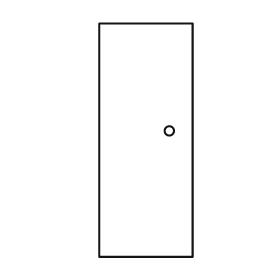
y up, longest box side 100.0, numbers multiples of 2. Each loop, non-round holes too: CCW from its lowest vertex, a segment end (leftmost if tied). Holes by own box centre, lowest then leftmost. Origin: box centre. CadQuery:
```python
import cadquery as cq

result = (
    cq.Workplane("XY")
    .moveTo(-20.0, -50.0)
    .lineTo(20.0, -50.0)
    .lineTo(20.0, 50.0)
    .lineTo(-20.0, 50.0)
    .close()
    .moveTo(10.0, 4.0)
    .circle(2.0)
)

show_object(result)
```